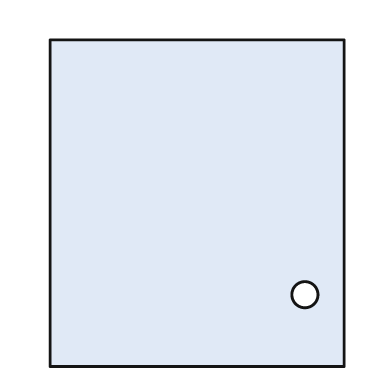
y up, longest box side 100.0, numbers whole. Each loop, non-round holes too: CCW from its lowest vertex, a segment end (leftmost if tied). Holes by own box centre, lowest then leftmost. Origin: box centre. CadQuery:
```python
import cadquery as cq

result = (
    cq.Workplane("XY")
    .moveTo(-45.0, -50.0)
    .lineTo(45.0, -50.0)
    .lineTo(45.0, 50.0)
    .lineTo(-45.0, 50.0)
    .close()
    .moveTo(33.0, -28.0)
    .circle(4.0)
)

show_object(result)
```